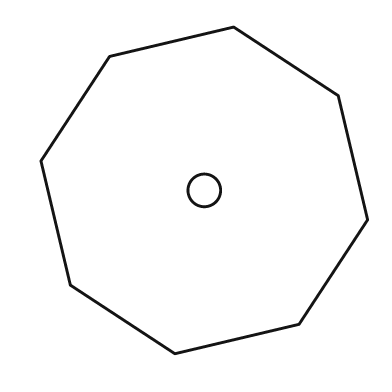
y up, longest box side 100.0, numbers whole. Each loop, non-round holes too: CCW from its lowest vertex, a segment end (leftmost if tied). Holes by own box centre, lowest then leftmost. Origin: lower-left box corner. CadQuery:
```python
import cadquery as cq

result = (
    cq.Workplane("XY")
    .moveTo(41.0, 0.0)
    .lineTo(79.0, 9.0)
    .lineTo(100.0, 41.0)
    .lineTo(91.0, 79.0)
    .lineTo(59.0, 100.0)
    .lineTo(21.0, 91.0)
    .lineTo(0.0, 59.0)
    .lineTo(9.0, 21.0)
    .close()
    .moveTo(50.0, 50.0)
    .circle(5.0)
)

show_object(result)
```